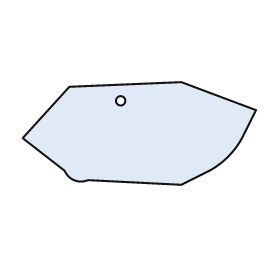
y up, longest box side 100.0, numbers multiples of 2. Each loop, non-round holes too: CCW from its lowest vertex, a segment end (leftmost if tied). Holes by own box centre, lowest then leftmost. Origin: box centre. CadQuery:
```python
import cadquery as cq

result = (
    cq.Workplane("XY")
    .moveTo(18.0, -22.0)
    .lineTo(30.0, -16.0)
    .threePointArc((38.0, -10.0), (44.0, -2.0))
    .lineTo(50.0, 10.0)
    .lineTo(18.0, 22.0)
    .lineTo(-30.0, 20.0)
    .lineTo(-50.0, -2.0)
    .lineTo(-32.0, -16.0)
    .threePointArc((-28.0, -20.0), (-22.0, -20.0))
    .close()
    .moveTo(-8.0, 14.0)
    .circle(2.0)
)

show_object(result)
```